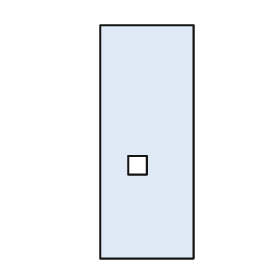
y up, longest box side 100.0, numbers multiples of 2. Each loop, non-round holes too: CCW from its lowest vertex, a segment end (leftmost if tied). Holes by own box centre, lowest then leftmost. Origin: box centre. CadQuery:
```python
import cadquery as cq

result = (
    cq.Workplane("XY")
    .moveTo(-20.0, -50.0)
    .lineTo(20.0, -50.0)
    .lineTo(20.0, 50.0)
    .lineTo(-20.0, 50.0)
    .close()
    .moveTo(-8.0, -14.0)
    .lineTo(0.0, -14.0)
    .lineTo(0.0, -6.0)
    .lineTo(-8.0, -6.0)
    .close()
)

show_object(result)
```